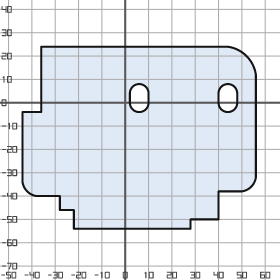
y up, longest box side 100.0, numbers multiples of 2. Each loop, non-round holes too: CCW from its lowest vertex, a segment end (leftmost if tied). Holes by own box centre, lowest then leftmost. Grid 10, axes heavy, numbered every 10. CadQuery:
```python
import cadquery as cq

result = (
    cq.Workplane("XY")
    .moveTo(-22.0, -54.0)
    .lineTo(28.0, -54.0)
    .lineTo(28.0, -50.0)
    .lineTo(40.0, -50.0)
    .lineTo(40.0, -38.0)
    .lineTo(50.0, -38.0)
    .threePointArc((54.0, -36.0), (56.0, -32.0))
    .lineTo(56.0, 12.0)
    .threePointArc((52.0, 20.0), (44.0, 24.0))
    .lineTo(-36.0, 24.0)
    .lineTo(-36.0, -4.0)
    .lineTo(-44.0, -4.0)
    .lineTo(-44.0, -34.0)
    .threePointArc((-42.0, -38.0), (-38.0, -40.0))
    .lineTo(-28.0, -40.0)
    .lineTo(-28.0, -46.0)
    .lineTo(-22.0, -46.0)
    .close()
    .moveTo(2.0, 0.0)
    .threePointArc((6.0, -4.0), (10.0, 0.0))
    .lineTo(10.0, 4.0)
    .threePointArc((6.0, 8.0), (2.0, 4.0))
    .close()
    .moveTo(40.0, 0.0)
    .threePointArc((44.0, -4.0), (48.0, 0.0))
    .lineTo(48.0, 4.0)
    .threePointArc((44.0, 8.0), (40.0, 4.0))
    .close()
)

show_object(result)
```